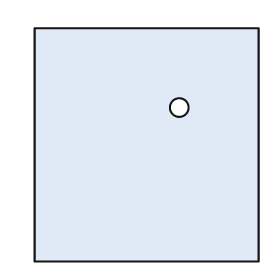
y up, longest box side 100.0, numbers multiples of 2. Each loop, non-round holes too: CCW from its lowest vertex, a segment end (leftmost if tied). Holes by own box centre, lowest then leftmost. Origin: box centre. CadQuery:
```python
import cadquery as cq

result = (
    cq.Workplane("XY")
    .moveTo(-48.0, -50.0)
    .lineTo(48.0, -50.0)
    .lineTo(48.0, 50.0)
    .lineTo(-48.0, 50.0)
    .close()
    .moveTo(14.0, 16.0)
    .circle(4.0)
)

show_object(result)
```